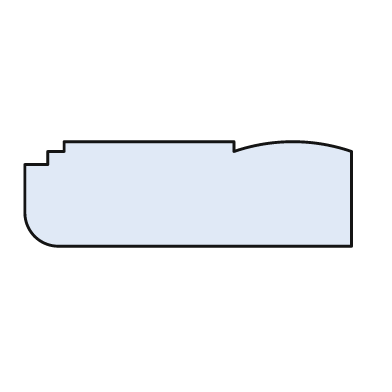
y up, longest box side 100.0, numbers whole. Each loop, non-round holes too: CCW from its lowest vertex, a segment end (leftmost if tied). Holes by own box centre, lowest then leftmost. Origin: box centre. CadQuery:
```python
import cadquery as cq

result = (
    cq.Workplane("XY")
    .moveTo(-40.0, -16.0)
    .lineTo(50.0, -16.0)
    .lineTo(50.0, 13.0)
    .threePointArc((32.0, 16.0), (14.0, 13.0))
    .lineTo(14.0, 16.0)
    .lineTo(-38.0, 16.0)
    .lineTo(-38.0, 13.0)
    .lineTo(-43.0, 13.0)
    .lineTo(-43.0, 9.0)
    .lineTo(-50.0, 9.0)
    .lineTo(-50.0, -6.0)
    .threePointArc((-47.0, -13.0), (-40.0, -16.0))
    .close()
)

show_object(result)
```